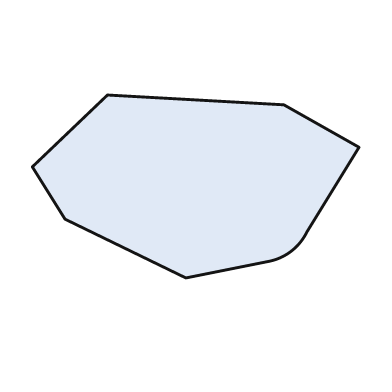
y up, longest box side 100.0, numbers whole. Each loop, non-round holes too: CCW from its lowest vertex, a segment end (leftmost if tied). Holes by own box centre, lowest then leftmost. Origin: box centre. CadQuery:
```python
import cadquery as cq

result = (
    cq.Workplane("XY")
    .moveTo(-3.0, -28.0)
    .lineTo(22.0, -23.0)
    .threePointArc((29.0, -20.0), (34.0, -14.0))
    .lineTo(50.0, 12.0)
    .lineTo(27.0, 25.0)
    .lineTo(-27.0, 28.0)
    .lineTo(-50.0, 6.0)
    .lineTo(-40.0, -10.0)
    .close()
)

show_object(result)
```